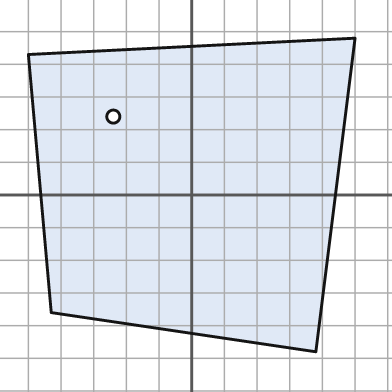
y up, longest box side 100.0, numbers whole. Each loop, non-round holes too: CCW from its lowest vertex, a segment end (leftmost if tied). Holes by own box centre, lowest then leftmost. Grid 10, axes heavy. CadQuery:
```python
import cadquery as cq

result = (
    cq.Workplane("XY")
    .moveTo(38.0, -48.0)
    .lineTo(50.0, 48.0)
    .lineTo(-50.0, 43.0)
    .lineTo(-43.0, -36.0)
    .close()
    .moveTo(-24.0, 24.0)
    .circle(2.0)
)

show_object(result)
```